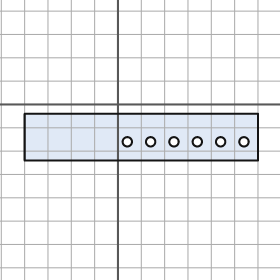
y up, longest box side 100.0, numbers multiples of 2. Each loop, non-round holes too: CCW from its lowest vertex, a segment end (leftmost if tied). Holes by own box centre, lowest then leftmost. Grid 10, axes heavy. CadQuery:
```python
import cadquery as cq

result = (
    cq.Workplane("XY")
    .moveTo(-40.0, -24.0)
    .lineTo(60.0, -24.0)
    .lineTo(60.0, -4.0)
    .lineTo(-40.0, -4.0)
    .close()
    .moveTo(4.0, -16.0)
    .circle(2.0)
    .moveTo(14.0, -16.0)
    .circle(2.0)
    .moveTo(24.0, -16.0)
    .circle(2.0)
    .moveTo(34.0, -16.0)
    .circle(2.0)
    .moveTo(44.0, -16.0)
    .circle(2.0)
    .moveTo(54.0, -16.0)
    .circle(2.0)
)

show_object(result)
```